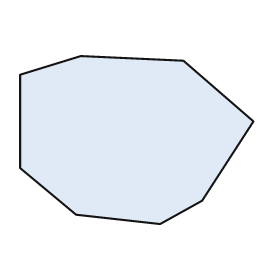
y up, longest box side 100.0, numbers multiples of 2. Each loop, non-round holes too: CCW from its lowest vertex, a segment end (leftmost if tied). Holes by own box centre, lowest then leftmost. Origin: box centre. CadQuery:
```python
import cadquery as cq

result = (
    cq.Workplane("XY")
    .moveTo(10.0, -36.0)
    .lineTo(28.0, -26.0)
    .lineTo(50.0, 8.0)
    .lineTo(20.0, 34.0)
    .lineTo(-24.0, 36.0)
    .lineTo(-50.0, 28.0)
    .lineTo(-50.0, -12.0)
    .lineTo(-26.0, -32.0)
    .close()
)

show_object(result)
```